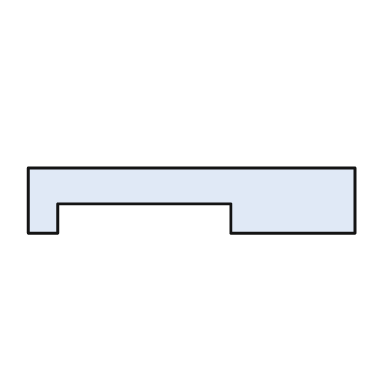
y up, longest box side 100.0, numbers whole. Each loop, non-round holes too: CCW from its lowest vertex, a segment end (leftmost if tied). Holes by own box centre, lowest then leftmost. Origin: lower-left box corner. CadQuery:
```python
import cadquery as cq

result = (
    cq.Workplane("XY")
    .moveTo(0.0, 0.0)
    .lineTo(9.0, 0.0)
    .lineTo(9.0, 9.0)
    .lineTo(62.0, 9.0)
    .lineTo(62.0, 0.0)
    .lineTo(100.0, 0.0)
    .lineTo(100.0, 20.0)
    .lineTo(0.0, 20.0)
    .close()
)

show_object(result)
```